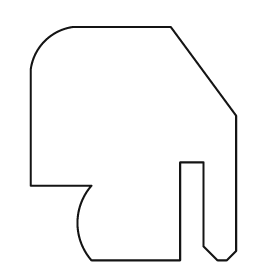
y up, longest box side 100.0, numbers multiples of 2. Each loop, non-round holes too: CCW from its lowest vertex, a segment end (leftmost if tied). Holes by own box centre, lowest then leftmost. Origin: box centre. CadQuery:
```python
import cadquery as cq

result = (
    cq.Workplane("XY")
    .moveTo(-18.0, -50.0)
    .lineTo(20.0, -50.0)
    .lineTo(20.0, -8.0)
    .lineTo(30.0, -8.0)
    .lineTo(30.0, -44.0)
    .lineTo(36.0, -50.0)
    .lineTo(40.0, -50.0)
    .lineTo(44.0, -46.0)
    .lineTo(44.0, 12.0)
    .lineTo(16.0, 50.0)
    .lineTo(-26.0, 50.0)
    .threePointArc((-38.0, 44.0), (-44.0, 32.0))
    .lineTo(-44.0, -18.0)
    .lineTo(-18.0, -18.0)
    .threePointArc((-24.0, -34.0), (-18.0, -50.0))
    .close()
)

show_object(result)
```